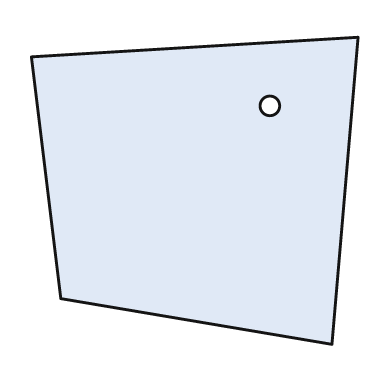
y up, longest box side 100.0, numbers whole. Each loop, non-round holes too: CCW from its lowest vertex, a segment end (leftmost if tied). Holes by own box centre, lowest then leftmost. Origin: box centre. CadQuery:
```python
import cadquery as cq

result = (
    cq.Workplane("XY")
    .moveTo(42.0, -47.0)
    .lineTo(50.0, 47.0)
    .lineTo(-50.0, 41.0)
    .lineTo(-41.0, -33.0)
    .close()
    .moveTo(23.0, 26.0)
    .circle(3.0)
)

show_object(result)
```